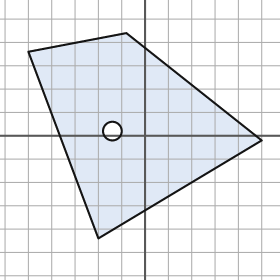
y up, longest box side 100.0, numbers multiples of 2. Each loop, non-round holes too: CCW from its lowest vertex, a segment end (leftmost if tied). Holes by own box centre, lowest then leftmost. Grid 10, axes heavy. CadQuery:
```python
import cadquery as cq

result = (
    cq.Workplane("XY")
    .moveTo(-20.0, -44.0)
    .lineTo(50.0, -2.0)
    .lineTo(-8.0, 44.0)
    .lineTo(-50.0, 36.0)
    .close()
    .moveTo(-14.0, 2.0)
    .circle(4.0)
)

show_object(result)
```